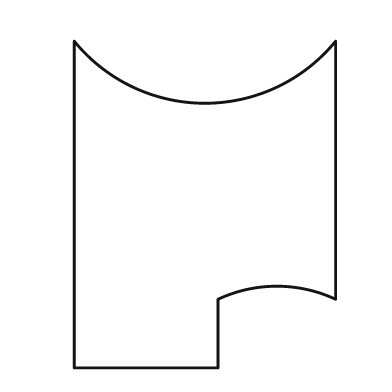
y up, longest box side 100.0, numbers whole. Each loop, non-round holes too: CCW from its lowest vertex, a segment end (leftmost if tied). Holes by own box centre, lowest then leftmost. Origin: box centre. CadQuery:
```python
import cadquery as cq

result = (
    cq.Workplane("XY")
    .moveTo(-40.0, -50.0)
    .lineTo(4.0, -50.0)
    .lineTo(4.0, -29.0)
    .threePointArc((22.0, -25.0), (40.0, -29.0))
    .lineTo(40.0, 50.0)
    .threePointArc((0.0, 31.0), (-40.0, 50.0))
    .close()
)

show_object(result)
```